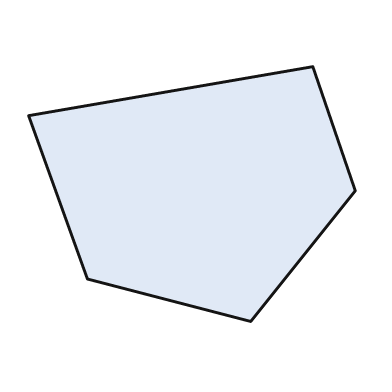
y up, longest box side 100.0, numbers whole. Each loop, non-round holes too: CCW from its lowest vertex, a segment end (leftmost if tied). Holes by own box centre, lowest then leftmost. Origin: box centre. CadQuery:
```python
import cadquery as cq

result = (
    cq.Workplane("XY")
    .moveTo(18.0, -39.0)
    .lineTo(50.0, 1.0)
    .lineTo(37.0, 39.0)
    .lineTo(-50.0, 24.0)
    .lineTo(-32.0, -26.0)
    .close()
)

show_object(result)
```